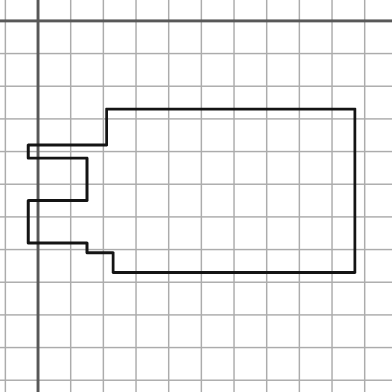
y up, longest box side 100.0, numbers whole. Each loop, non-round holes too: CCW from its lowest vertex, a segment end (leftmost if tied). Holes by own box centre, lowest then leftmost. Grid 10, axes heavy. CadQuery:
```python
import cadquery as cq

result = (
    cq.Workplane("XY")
    .moveTo(23.0, -77.0)
    .lineTo(97.0, -77.0)
    .lineTo(97.0, -27.0)
    .lineTo(21.0, -27.0)
    .lineTo(21.0, -38.0)
    .lineTo(-3.0, -38.0)
    .lineTo(-3.0, -42.0)
    .lineTo(15.0, -42.0)
    .lineTo(15.0, -55.0)
    .lineTo(-3.0, -55.0)
    .lineTo(-3.0, -68.0)
    .lineTo(15.0, -68.0)
    .lineTo(15.0, -71.0)
    .lineTo(23.0, -71.0)
    .close()
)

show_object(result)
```